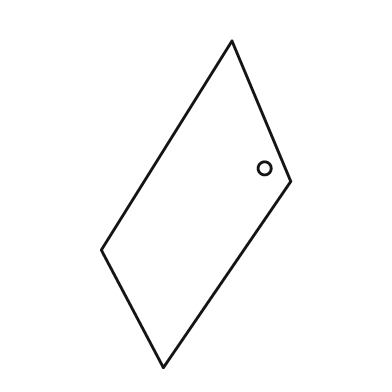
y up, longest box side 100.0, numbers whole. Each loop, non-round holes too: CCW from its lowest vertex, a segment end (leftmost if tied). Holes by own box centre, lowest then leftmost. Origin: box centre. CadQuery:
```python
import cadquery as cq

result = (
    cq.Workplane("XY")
    .moveTo(-10.0, -50.0)
    .lineTo(29.0, 7.0)
    .lineTo(11.0, 50.0)
    .lineTo(-29.0, -14.0)
    .close()
    .moveTo(21.0, 11.0)
    .circle(2.0)
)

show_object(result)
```